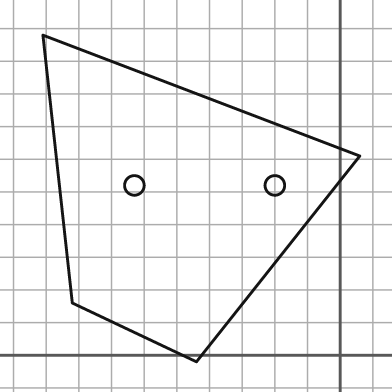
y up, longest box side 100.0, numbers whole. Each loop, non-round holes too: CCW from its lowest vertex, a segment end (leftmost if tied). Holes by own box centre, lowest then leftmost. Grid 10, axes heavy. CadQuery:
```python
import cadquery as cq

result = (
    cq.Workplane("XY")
    .moveTo(-44.0, -2.0)
    .lineTo(6.0, 61.0)
    .lineTo(-91.0, 98.0)
    .lineTo(-82.0, 16.0)
    .close()
    .moveTo(-63.0, 52.0)
    .circle(3.0)
    .moveTo(-20.0, 52.0)
    .circle(3.0)
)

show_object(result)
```